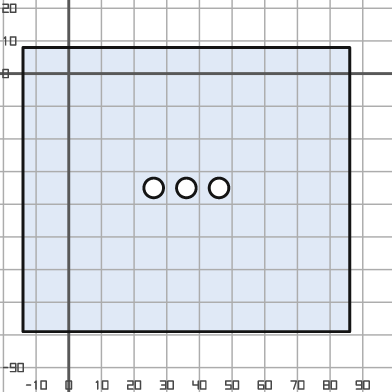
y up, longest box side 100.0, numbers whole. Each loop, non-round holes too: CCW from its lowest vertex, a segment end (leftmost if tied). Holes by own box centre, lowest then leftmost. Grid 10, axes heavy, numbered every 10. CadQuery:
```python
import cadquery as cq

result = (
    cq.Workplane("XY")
    .moveTo(-14.0, -79.0)
    .lineTo(86.0, -79.0)
    .lineTo(86.0, 8.0)
    .lineTo(-14.0, 8.0)
    .close()
    .moveTo(26.0, -35.0)
    .circle(3.0)
    .moveTo(36.0, -35.0)
    .circle(3.0)
    .moveTo(46.0, -35.0)
    .circle(3.0)
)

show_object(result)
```